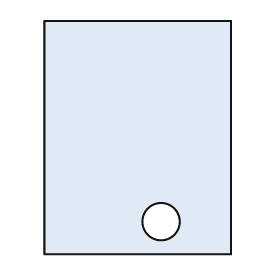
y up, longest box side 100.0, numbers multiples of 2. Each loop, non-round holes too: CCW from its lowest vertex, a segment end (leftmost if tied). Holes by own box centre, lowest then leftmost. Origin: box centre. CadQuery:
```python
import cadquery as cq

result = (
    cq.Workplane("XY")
    .moveTo(-40.0, -50.0)
    .lineTo(40.0, -50.0)
    .lineTo(40.0, 50.0)
    .lineTo(-40.0, 50.0)
    .close()
    .moveTo(10.0, -36.0)
    .circle(8.0)
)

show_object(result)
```